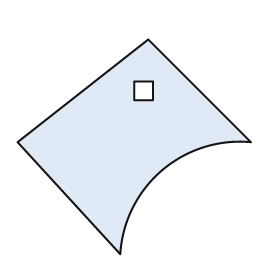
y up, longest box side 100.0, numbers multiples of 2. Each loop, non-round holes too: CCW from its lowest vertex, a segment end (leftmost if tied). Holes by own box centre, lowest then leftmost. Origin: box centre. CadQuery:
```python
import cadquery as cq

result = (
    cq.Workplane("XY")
    .moveTo(-6.0, -46.0)
    .threePointArc((12.0, -10.0), (50.0, 2.0))
    .lineTo(6.0, 46.0)
    .lineTo(-50.0, 2.0)
    .close()
    .moveTo(0.0, 20.0)
    .lineTo(8.0, 20.0)
    .lineTo(8.0, 28.0)
    .lineTo(0.0, 28.0)
    .close()
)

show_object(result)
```